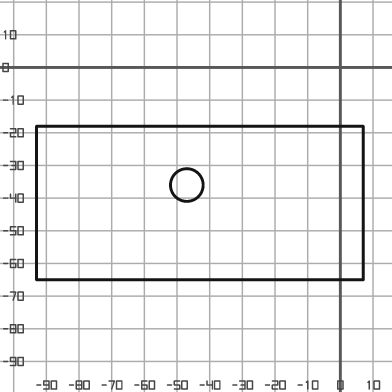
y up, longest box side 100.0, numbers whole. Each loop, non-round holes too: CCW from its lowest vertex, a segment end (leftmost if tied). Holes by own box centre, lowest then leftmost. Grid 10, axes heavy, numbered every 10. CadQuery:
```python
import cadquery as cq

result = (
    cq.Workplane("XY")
    .moveTo(-93.0, -65.0)
    .lineTo(7.0, -65.0)
    .lineTo(7.0, -18.0)
    .lineTo(-93.0, -18.0)
    .close()
    .moveTo(-47.0, -36.0)
    .circle(5.0)
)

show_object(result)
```